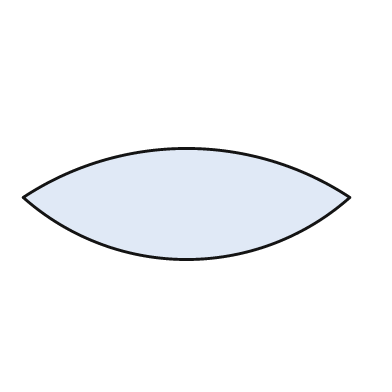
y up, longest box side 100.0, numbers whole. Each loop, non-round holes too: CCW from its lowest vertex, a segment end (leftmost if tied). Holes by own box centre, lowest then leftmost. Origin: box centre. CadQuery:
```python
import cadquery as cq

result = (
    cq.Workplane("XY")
    .moveTo(-50.0, 2.0)
    .threePointArc((0.0, -17.0), (50.0, 2.0))
    .threePointArc((0.0, 17.0), (-50.0, 2.0))
    .close()
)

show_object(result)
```